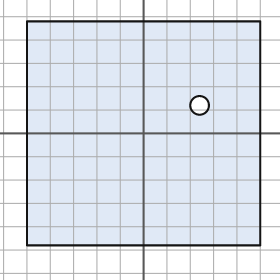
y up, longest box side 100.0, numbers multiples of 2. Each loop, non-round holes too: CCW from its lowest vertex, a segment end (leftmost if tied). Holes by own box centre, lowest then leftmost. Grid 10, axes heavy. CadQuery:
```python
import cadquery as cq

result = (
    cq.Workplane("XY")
    .moveTo(-50.0, -48.0)
    .lineTo(50.0, -48.0)
    .lineTo(50.0, 48.0)
    .lineTo(-50.0, 48.0)
    .close()
    .moveTo(24.0, 12.0)
    .circle(4.0)
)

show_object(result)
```